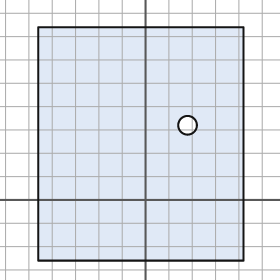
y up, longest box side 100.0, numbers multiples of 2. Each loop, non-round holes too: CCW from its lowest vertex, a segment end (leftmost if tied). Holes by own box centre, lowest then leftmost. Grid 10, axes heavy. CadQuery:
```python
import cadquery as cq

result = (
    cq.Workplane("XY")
    .moveTo(-46.0, -26.0)
    .lineTo(42.0, -26.0)
    .lineTo(42.0, 74.0)
    .lineTo(-46.0, 74.0)
    .close()
    .moveTo(18.0, 32.0)
    .circle(4.0)
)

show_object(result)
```